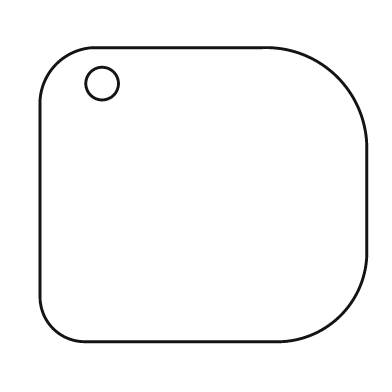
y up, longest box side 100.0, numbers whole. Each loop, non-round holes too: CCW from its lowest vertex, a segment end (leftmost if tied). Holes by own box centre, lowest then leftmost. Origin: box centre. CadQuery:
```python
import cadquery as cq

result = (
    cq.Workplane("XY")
    .moveTo(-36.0, -45.0)
    .lineTo(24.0, -45.0)
    .threePointArc((42.0, -37.0), (50.0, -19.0))
    .lineTo(50.0, 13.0)
    .threePointArc((41.0, 36.0), (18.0, 45.0))
    .lineTo(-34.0, 45.0)
    .threePointArc((-45.0, 40.0), (-50.0, 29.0))
    .lineTo(-50.0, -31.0)
    .threePointArc((-46.0, -41.0), (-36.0, -45.0))
    .close()
    .moveTo(-31.0, 34.0)
    .circle(5.0)
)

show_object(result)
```